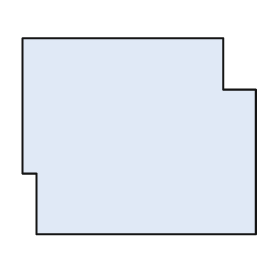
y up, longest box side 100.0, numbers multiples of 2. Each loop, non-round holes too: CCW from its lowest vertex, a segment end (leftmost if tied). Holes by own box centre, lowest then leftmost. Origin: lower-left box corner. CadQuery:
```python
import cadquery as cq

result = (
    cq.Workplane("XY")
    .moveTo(6.0, 0.0)
    .lineTo(100.0, 0.0)
    .lineTo(100.0, 62.0)
    .lineTo(86.0, 62.0)
    .lineTo(86.0, 84.0)
    .lineTo(0.0, 84.0)
    .lineTo(0.0, 26.0)
    .lineTo(6.0, 26.0)
    .close()
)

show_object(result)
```